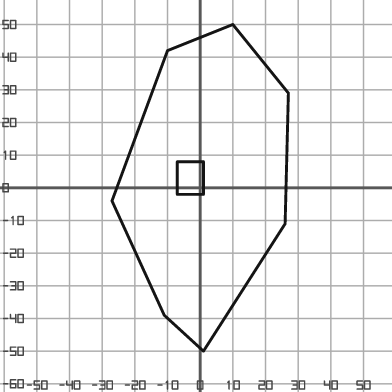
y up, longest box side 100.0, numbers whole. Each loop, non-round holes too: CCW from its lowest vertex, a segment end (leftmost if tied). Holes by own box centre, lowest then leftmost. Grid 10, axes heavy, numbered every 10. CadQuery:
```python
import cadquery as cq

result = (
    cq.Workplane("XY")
    .moveTo(1.0, -50.0)
    .lineTo(26.0, -11.0)
    .lineTo(27.0, 29.0)
    .lineTo(10.0, 50.0)
    .lineTo(-10.0, 42.0)
    .lineTo(-27.0, -4.0)
    .lineTo(-11.0, -39.0)
    .close()
    .moveTo(-7.0, -2.0)
    .lineTo(1.0, -2.0)
    .lineTo(1.0, 8.0)
    .lineTo(-7.0, 8.0)
    .close()
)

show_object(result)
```